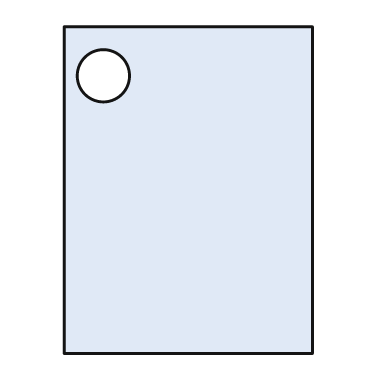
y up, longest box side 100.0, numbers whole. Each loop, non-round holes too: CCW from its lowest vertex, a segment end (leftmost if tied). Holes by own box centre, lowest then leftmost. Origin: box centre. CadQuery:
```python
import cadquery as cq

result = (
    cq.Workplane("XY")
    .moveTo(-38.0, -50.0)
    .lineTo(38.0, -50.0)
    .lineTo(38.0, 50.0)
    .lineTo(-38.0, 50.0)
    .close()
    .moveTo(-26.0, 35.0)
    .circle(8.0)
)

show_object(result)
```